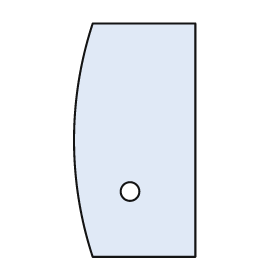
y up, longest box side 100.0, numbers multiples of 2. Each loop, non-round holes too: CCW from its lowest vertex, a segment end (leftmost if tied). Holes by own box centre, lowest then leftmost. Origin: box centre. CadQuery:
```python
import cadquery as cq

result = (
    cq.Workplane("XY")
    .moveTo(-18.0, -50.0)
    .lineTo(26.0, -50.0)
    .lineTo(26.0, 50.0)
    .lineTo(-18.0, 50.0)
    .threePointArc((-26.0, 0.0), (-18.0, -50.0))
    .close()
    .moveTo(-2.0, -22.0)
    .circle(4.0)
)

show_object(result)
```